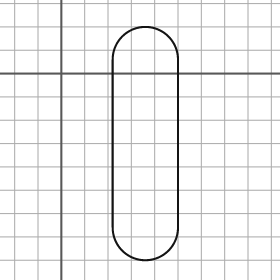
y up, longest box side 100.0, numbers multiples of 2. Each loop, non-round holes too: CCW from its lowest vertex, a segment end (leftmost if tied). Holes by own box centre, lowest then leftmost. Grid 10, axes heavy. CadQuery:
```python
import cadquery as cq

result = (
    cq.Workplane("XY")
    .moveTo(22.0, -66.0)
    .threePointArc((36.0, -80.0), (50.0, -66.0))
    .lineTo(50.0, 6.0)
    .threePointArc((36.0, 20.0), (22.0, 6.0))
    .close()
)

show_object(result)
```